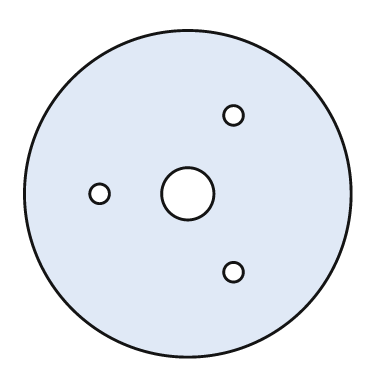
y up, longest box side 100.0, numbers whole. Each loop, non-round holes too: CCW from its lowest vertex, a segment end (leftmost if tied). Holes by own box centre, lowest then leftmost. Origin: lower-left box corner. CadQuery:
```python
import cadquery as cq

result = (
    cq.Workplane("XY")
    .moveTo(50.0, 50.0)
    .circle(50.0)
    .moveTo(64.0, 26.0)
    .circle(3.0)
    .moveTo(23.0, 50.0)
    .circle(3.0)
    .moveTo(50.0, 50.0)
    .circle(8.0)
    .moveTo(64.0, 74.0)
    .circle(3.0)
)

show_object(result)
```